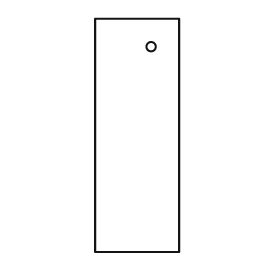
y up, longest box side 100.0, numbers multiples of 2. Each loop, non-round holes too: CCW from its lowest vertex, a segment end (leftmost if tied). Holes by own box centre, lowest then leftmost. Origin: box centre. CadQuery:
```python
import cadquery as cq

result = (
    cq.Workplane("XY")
    .moveTo(-18.0, -50.0)
    .lineTo(18.0, -50.0)
    .lineTo(18.0, 50.0)
    .lineTo(-18.0, 50.0)
    .close()
    .moveTo(6.0, 38.0)
    .circle(2.0)
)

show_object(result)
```